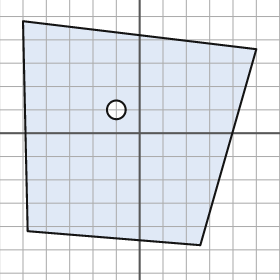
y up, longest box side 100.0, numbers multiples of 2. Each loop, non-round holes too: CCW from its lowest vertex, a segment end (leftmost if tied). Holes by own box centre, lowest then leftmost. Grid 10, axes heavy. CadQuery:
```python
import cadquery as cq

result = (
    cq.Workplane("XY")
    .moveTo(26.0, -48.0)
    .lineTo(50.0, 36.0)
    .lineTo(-50.0, 48.0)
    .lineTo(-48.0, -42.0)
    .close()
    .moveTo(-10.0, 10.0)
    .circle(4.0)
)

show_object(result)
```